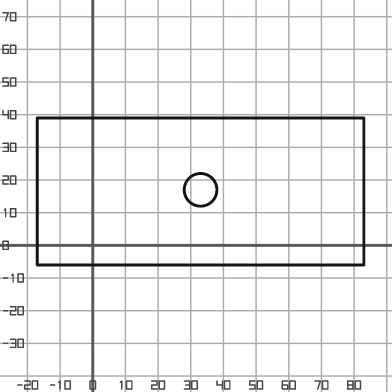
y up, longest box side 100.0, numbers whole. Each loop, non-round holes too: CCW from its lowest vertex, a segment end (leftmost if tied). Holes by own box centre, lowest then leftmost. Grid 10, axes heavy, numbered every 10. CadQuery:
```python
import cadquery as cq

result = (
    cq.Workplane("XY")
    .moveTo(-17.0, -6.0)
    .lineTo(83.0, -6.0)
    .lineTo(83.0, 39.0)
    .lineTo(-17.0, 39.0)
    .close()
    .moveTo(33.0, 17.0)
    .circle(5.0)
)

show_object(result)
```